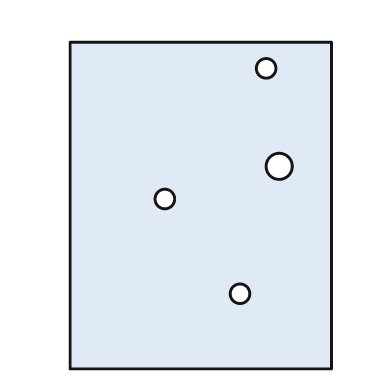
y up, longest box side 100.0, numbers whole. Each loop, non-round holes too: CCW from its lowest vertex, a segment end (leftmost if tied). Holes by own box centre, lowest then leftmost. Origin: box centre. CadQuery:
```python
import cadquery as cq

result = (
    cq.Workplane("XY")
    .moveTo(-40.0, -50.0)
    .lineTo(40.0, -50.0)
    .lineTo(40.0, 50.0)
    .lineTo(-40.0, 50.0)
    .close()
    .moveTo(12.0, -27.0)
    .circle(3.0)
    .moveTo(-11.0, 2.0)
    .circle(3.0)
    .moveTo(24.0, 12.0)
    .circle(4.0)
    .moveTo(20.0, 42.0)
    .circle(3.0)
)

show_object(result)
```